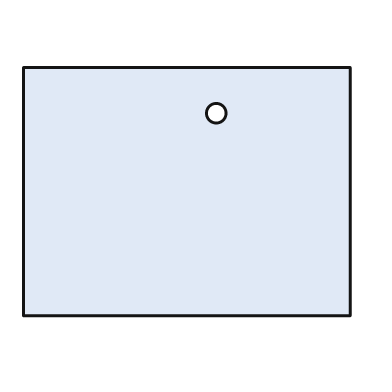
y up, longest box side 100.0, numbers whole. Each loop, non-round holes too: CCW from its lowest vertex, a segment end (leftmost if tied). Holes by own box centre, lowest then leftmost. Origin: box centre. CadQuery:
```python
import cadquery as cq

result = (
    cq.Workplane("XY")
    .moveTo(-50.0, -38.0)
    .lineTo(50.0, -38.0)
    .lineTo(50.0, 38.0)
    .lineTo(-50.0, 38.0)
    .close()
    .moveTo(9.0, 24.0)
    .circle(3.0)
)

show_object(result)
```